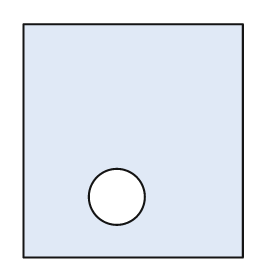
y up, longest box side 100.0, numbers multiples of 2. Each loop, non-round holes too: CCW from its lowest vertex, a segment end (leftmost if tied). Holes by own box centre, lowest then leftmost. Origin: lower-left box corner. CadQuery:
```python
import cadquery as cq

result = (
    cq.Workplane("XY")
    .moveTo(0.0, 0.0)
    .lineTo(94.0, 0.0)
    .lineTo(94.0, 100.0)
    .lineTo(0.0, 100.0)
    .close()
    .moveTo(40.0, 26.0)
    .circle(12.0)
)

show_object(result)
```